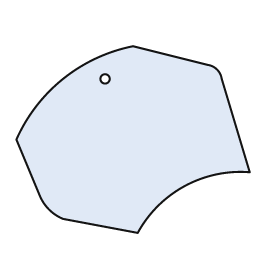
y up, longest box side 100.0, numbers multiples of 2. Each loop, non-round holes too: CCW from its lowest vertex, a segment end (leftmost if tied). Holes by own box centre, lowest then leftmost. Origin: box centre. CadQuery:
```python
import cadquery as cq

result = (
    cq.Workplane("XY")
    .moveTo(2.0, -40.0)
    .threePointArc((22.0, -20.0), (50.0, -14.0))
    .lineTo(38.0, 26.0)
    .threePointArc((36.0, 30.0), (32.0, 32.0))
    .lineTo(0.0, 40.0)
    .threePointArc((-30.0, 26.0), (-50.0, 0.0))
    .lineTo(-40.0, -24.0)
    .threePointArc((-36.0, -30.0), (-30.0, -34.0))
    .close()
    .moveTo(-12.0, 26.0)
    .circle(2.0)
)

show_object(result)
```